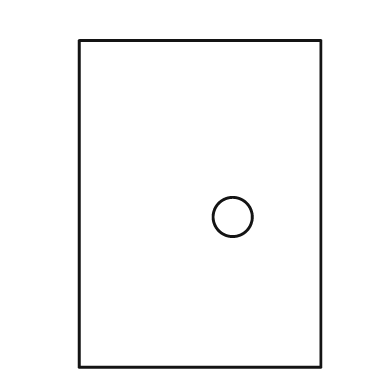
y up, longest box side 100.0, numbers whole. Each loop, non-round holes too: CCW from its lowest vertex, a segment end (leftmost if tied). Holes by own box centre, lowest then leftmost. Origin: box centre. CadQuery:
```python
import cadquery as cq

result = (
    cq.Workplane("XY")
    .moveTo(-37.0, -50.0)
    .lineTo(37.0, -50.0)
    .lineTo(37.0, 50.0)
    .lineTo(-37.0, 50.0)
    .close()
    .moveTo(10.0, -4.0)
    .circle(6.0)
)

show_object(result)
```